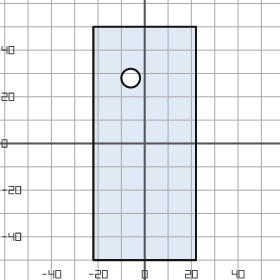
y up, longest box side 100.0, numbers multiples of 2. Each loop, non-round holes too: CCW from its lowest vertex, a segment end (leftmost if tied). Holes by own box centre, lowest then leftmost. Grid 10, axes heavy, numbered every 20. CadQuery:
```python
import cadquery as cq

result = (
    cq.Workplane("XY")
    .moveTo(-22.0, -50.0)
    .lineTo(22.0, -50.0)
    .lineTo(22.0, 50.0)
    .lineTo(-22.0, 50.0)
    .close()
    .moveTo(-6.0, 28.0)
    .circle(4.0)
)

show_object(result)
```